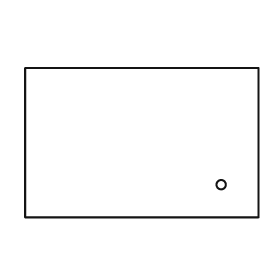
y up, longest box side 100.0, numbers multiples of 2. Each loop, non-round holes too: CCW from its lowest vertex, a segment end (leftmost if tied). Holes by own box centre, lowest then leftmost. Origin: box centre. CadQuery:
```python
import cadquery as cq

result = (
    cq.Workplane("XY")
    .moveTo(-50.0, -32.0)
    .lineTo(50.0, -32.0)
    .lineTo(50.0, 32.0)
    .lineTo(-50.0, 32.0)
    .close()
    .moveTo(34.0, -18.0)
    .circle(2.0)
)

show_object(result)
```